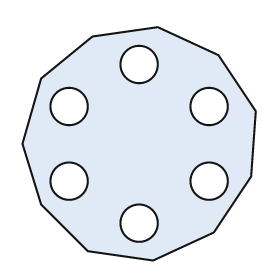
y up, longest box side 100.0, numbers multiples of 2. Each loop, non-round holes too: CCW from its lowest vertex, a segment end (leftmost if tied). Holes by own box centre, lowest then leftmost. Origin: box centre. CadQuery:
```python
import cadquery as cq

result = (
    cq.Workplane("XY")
    .moveTo(6.0, -50.0)
    .lineTo(32.0, -38.0)
    .lineTo(48.0, -14.0)
    .lineTo(50.0, 14.0)
    .lineTo(34.0, 38.0)
    .lineTo(8.0, 50.0)
    .lineTo(-20.0, 46.0)
    .lineTo(-42.0, 28.0)
    .lineTo(-50.0, 0.0)
    .lineTo(-42.0, -26.0)
    .lineTo(-22.0, -46.0)
    .close()
    .moveTo(0.0, -34.0)
    .circle(8.0)
    .moveTo(-30.0, -16.0)
    .circle(8.0)
    .moveTo(30.0, -16.0)
    .circle(8.0)
    .moveTo(-30.0, 16.0)
    .circle(8.0)
    .moveTo(30.0, 16.0)
    .circle(8.0)
    .moveTo(0.0, 34.0)
    .circle(8.0)
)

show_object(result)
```